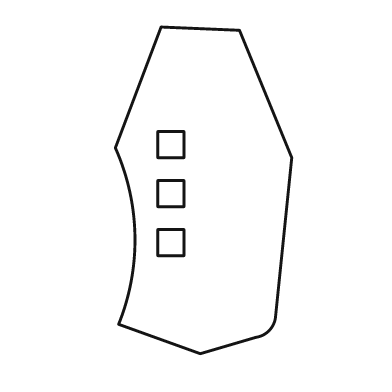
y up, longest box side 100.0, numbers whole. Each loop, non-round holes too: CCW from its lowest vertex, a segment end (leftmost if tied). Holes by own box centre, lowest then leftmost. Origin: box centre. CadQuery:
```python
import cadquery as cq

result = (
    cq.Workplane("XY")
    .moveTo(-1.0, -50.0)
    .lineTo(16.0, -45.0)
    .threePointArc((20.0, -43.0), (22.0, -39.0))
    .lineTo(27.0, 10.0)
    .lineTo(11.0, 49.0)
    .lineTo(-13.0, 50.0)
    .lineTo(-27.0, 13.0)
    .threePointArc((-21.0, -14.0), (-26.0, -41.0))
    .close()
    .moveTo(-14.0, -20.0)
    .lineTo(-6.0, -20.0)
    .lineTo(-6.0, -12.0)
    .lineTo(-14.0, -12.0)
    .close()
    .moveTo(-14.0, -5.0)
    .lineTo(-6.0, -5.0)
    .lineTo(-6.0, 3.0)
    .lineTo(-14.0, 3.0)
    .close()
    .moveTo(-14.0, 10.0)
    .lineTo(-6.0, 10.0)
    .lineTo(-6.0, 18.0)
    .lineTo(-14.0, 18.0)
    .close()
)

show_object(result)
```